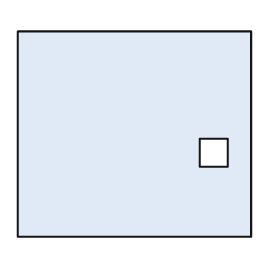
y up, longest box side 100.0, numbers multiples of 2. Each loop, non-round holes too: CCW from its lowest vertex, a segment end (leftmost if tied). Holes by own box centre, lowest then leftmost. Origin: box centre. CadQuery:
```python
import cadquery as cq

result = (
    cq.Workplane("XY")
    .moveTo(-50.0, -44.0)
    .lineTo(50.0, -44.0)
    .lineTo(50.0, 44.0)
    .lineTo(-50.0, 44.0)
    .close()
    .moveTo(28.0, -14.0)
    .lineTo(40.0, -14.0)
    .lineTo(40.0, -2.0)
    .lineTo(28.0, -2.0)
    .close()
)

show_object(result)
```